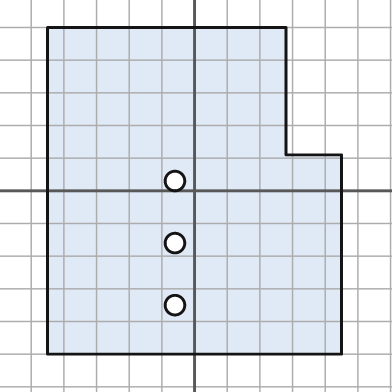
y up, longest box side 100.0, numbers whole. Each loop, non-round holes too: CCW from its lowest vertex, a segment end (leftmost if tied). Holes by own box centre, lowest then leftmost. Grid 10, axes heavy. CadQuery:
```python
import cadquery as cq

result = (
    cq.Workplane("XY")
    .moveTo(-45.0, -50.0)
    .lineTo(45.0, -50.0)
    .lineTo(45.0, 11.0)
    .lineTo(28.0, 11.0)
    .lineTo(28.0, 50.0)
    .lineTo(-45.0, 50.0)
    .close()
    .moveTo(-6.0, -35.0)
    .circle(3.0)
    .moveTo(-6.0, -16.0)
    .circle(3.0)
    .moveTo(-6.0, 3.0)
    .circle(3.0)
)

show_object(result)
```